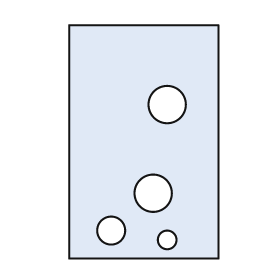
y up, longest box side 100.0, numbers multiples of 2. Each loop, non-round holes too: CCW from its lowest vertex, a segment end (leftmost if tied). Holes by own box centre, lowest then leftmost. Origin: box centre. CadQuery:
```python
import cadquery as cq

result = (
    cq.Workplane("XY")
    .moveTo(-32.0, -50.0)
    .lineTo(32.0, -50.0)
    .lineTo(32.0, 50.0)
    .lineTo(-32.0, 50.0)
    .close()
    .moveTo(10.0, -42.0)
    .circle(4.0)
    .moveTo(-14.0, -38.0)
    .circle(6.0)
    .moveTo(4.0, -22.0)
    .circle(8.0)
    .moveTo(10.0, 16.0)
    .circle(8.0)
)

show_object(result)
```